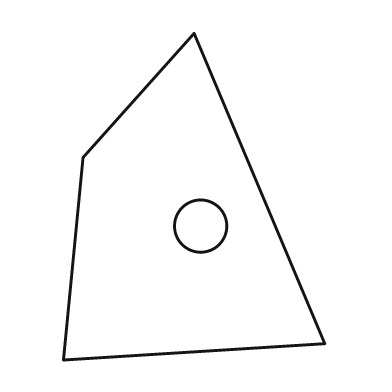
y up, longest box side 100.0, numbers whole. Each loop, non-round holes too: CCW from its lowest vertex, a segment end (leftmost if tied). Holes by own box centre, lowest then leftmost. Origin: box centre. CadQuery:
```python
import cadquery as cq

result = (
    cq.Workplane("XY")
    .moveTo(-40.0, -50.0)
    .lineTo(40.0, -45.0)
    .lineTo(0.0, 50.0)
    .lineTo(-34.0, 12.0)
    .close()
    .moveTo(2.0, -9.0)
    .circle(8.0)
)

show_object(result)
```